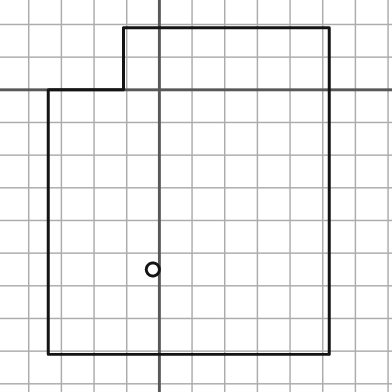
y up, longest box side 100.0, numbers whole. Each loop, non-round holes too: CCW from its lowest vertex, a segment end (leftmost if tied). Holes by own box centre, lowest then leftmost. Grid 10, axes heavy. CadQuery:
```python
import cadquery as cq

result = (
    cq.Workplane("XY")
    .moveTo(-34.0, -81.0)
    .lineTo(52.0, -81.0)
    .lineTo(52.0, 19.0)
    .lineTo(-11.0, 19.0)
    .lineTo(-11.0, 0.0)
    .lineTo(-34.0, 0.0)
    .close()
    .moveTo(-2.0, -55.0)
    .circle(2.0)
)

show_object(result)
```